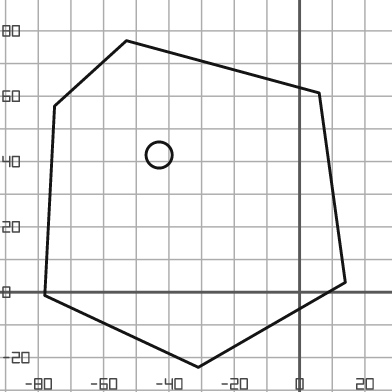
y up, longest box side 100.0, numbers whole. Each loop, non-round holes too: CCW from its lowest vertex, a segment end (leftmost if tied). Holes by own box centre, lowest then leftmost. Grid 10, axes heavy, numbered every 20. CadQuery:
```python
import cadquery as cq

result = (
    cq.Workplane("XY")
    .moveTo(-31.0, -23.0)
    .lineTo(14.0, 3.0)
    .lineTo(6.0, 61.0)
    .lineTo(-53.0, 77.0)
    .lineTo(-75.0, 57.0)
    .lineTo(-78.0, -1.0)
    .close()
    .moveTo(-43.0, 42.0)
    .circle(4.0)
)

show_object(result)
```